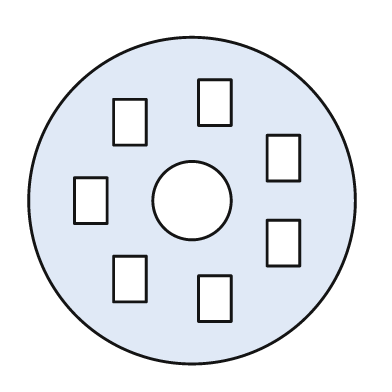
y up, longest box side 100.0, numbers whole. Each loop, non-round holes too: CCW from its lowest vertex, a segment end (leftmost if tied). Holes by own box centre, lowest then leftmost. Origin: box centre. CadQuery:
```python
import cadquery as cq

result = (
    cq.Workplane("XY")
    .moveTo(0.0, 0.0)
    .circle(50.0)
    .moveTo(2.0, -37.0)
    .lineTo(12.0, -37.0)
    .lineTo(12.0, -23.0)
    .lineTo(2.0, -23.0)
    .close()
    .moveTo(-24.0, -31.0)
    .lineTo(-14.0, -31.0)
    .lineTo(-14.0, -17.0)
    .lineTo(-24.0, -17.0)
    .close()
    .moveTo(23.0, -20.0)
    .lineTo(33.0, -20.0)
    .lineTo(33.0, -6.0)
    .lineTo(23.0, -6.0)
    .close()
    .moveTo(-36.0, -7.0)
    .lineTo(-26.0, -7.0)
    .lineTo(-26.0, 7.0)
    .lineTo(-36.0, 7.0)
    .close()
    .moveTo(0.0, 0.0)
    .circle(12.0)
    .moveTo(23.0, 6.0)
    .lineTo(33.0, 6.0)
    .lineTo(33.0, 20.0)
    .lineTo(23.0, 20.0)
    .close()
    .moveTo(-24.0, 17.0)
    .lineTo(-14.0, 17.0)
    .lineTo(-14.0, 31.0)
    .lineTo(-24.0, 31.0)
    .close()
    .moveTo(2.0, 23.0)
    .lineTo(12.0, 23.0)
    .lineTo(12.0, 37.0)
    .lineTo(2.0, 37.0)
    .close()
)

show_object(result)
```